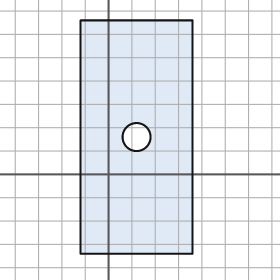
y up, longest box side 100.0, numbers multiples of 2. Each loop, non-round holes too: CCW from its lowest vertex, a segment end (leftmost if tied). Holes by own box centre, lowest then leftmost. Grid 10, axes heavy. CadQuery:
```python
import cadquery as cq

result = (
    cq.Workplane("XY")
    .moveTo(-12.0, -34.0)
    .lineTo(36.0, -34.0)
    .lineTo(36.0, 66.0)
    .lineTo(-12.0, 66.0)
    .close()
    .moveTo(12.0, 16.0)
    .circle(6.0)
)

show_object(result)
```